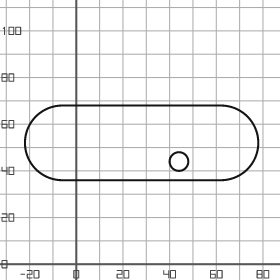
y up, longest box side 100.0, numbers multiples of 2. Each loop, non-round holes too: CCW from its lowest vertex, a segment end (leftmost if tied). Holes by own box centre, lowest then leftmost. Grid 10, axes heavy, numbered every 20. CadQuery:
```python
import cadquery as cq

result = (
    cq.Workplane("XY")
    .moveTo(-6.0, 36.0)
    .lineTo(62.0, 36.0)
    .threePointArc((78.0, 52.0), (62.0, 68.0))
    .lineTo(-6.0, 68.0)
    .threePointArc((-22.0, 52.0), (-6.0, 36.0))
    .close()
    .moveTo(44.0, 44.0)
    .circle(4.0)
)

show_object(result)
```